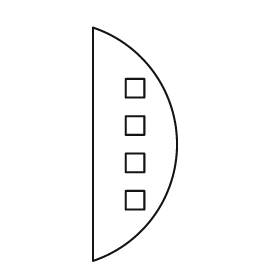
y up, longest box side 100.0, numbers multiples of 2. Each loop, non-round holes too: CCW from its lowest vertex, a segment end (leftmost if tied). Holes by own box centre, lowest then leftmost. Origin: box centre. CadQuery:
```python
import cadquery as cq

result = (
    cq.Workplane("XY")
    .moveTo(-18.0, -50.0)
    .threePointArc((18.0, 0.0), (-18.0, 50.0))
    .close()
    .moveTo(-4.0, -28.0)
    .lineTo(4.0, -28.0)
    .lineTo(4.0, -20.0)
    .lineTo(-4.0, -20.0)
    .close()
    .moveTo(-4.0, -12.0)
    .lineTo(4.0, -12.0)
    .lineTo(4.0, -4.0)
    .lineTo(-4.0, -4.0)
    .close()
    .moveTo(-4.0, 4.0)
    .lineTo(4.0, 4.0)
    .lineTo(4.0, 12.0)
    .lineTo(-4.0, 12.0)
    .close()
    .moveTo(-4.0, 20.0)
    .lineTo(4.0, 20.0)
    .lineTo(4.0, 28.0)
    .lineTo(-4.0, 28.0)
    .close()
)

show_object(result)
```